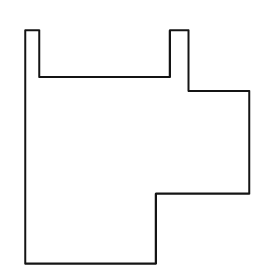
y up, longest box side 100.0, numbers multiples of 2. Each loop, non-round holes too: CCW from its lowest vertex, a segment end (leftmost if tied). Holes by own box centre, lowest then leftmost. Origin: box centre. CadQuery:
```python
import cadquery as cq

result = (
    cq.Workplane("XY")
    .moveTo(-48.0, -50.0)
    .lineTo(8.0, -50.0)
    .lineTo(8.0, -20.0)
    .lineTo(48.0, -20.0)
    .lineTo(48.0, 24.0)
    .lineTo(22.0, 24.0)
    .lineTo(22.0, 50.0)
    .lineTo(14.0, 50.0)
    .lineTo(14.0, 30.0)
    .lineTo(-42.0, 30.0)
    .lineTo(-42.0, 50.0)
    .lineTo(-48.0, 50.0)
    .close()
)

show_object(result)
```